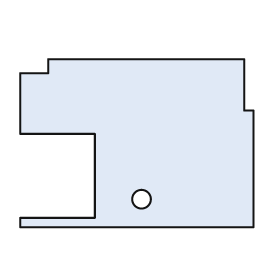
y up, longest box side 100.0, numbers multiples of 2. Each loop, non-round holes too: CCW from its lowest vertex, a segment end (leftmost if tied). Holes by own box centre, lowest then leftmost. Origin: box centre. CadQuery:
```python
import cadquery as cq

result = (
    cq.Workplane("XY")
    .moveTo(-50.0, -36.0)
    .lineTo(50.0, -36.0)
    .lineTo(50.0, 14.0)
    .lineTo(46.0, 14.0)
    .lineTo(46.0, 36.0)
    .lineTo(-38.0, 36.0)
    .lineTo(-38.0, 30.0)
    .lineTo(-50.0, 30.0)
    .lineTo(-50.0, 4.0)
    .lineTo(-18.0, 4.0)
    .lineTo(-18.0, -32.0)
    .lineTo(-50.0, -32.0)
    .close()
    .moveTo(2.0, -24.0)
    .circle(4.0)
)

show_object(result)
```